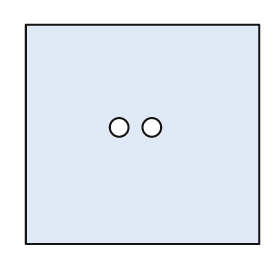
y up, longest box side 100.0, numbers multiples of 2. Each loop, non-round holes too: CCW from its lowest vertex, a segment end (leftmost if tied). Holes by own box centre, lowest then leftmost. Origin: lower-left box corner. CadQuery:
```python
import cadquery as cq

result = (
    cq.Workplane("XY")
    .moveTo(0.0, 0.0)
    .lineTo(100.0, 0.0)
    .lineTo(100.0, 94.0)
    .lineTo(0.0, 94.0)
    .close()
    .moveTo(40.0, 50.0)
    .circle(4.0)
    .moveTo(54.0, 50.0)
    .circle(4.0)
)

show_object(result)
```